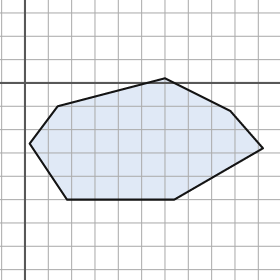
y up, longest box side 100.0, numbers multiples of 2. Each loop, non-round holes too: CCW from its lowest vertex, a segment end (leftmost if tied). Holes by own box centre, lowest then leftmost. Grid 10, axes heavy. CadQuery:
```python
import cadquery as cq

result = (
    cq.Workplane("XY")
    .moveTo(18.0, -50.0)
    .lineTo(64.0, -50.0)
    .lineTo(102.0, -28.0)
    .lineTo(88.0, -12.0)
    .lineTo(60.0, 2.0)
    .lineTo(14.0, -10.0)
    .lineTo(2.0, -26.0)
    .close()
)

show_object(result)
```